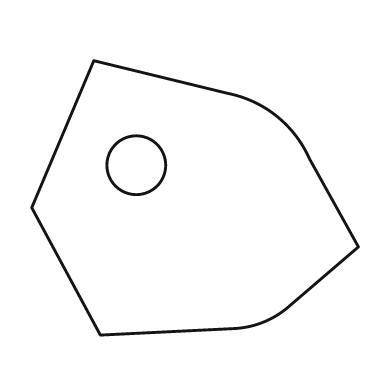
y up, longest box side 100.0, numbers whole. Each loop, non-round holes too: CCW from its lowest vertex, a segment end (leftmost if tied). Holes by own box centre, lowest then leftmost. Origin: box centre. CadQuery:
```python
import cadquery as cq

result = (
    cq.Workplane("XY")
    .moveTo(-29.0, -42.0)
    .lineTo(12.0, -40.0)
    .threePointArc((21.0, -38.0), (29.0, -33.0))
    .lineTo(50.0, -15.0)
    .lineTo(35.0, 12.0)
    .threePointArc((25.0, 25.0), (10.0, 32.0))
    .lineTo(-31.0, 42.0)
    .lineTo(-50.0, -3.0)
    .close()
    .moveTo(-18.0, 10.0)
    .circle(9.0)
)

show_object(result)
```